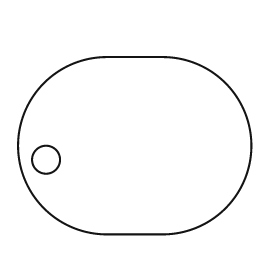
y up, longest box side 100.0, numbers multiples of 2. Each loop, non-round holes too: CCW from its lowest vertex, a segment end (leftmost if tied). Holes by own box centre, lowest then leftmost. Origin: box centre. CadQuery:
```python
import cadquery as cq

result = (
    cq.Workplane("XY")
    .moveTo(-12.0, -38.0)
    .lineTo(12.0, -38.0)
    .threePointArc((50.0, 0.0), (12.0, 38.0))
    .lineTo(-12.0, 38.0)
    .threePointArc((-50.0, 0.0), (-12.0, -38.0))
    .close()
    .moveTo(-38.0, -6.0)
    .circle(6.0)
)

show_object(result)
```